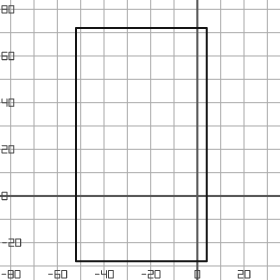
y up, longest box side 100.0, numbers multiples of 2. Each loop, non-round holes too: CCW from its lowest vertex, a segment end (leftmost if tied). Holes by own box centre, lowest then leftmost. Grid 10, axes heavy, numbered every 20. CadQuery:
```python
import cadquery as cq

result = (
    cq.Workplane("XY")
    .moveTo(-52.0, -28.0)
    .lineTo(4.0, -28.0)
    .lineTo(4.0, 72.0)
    .lineTo(-52.0, 72.0)
    .close()
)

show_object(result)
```